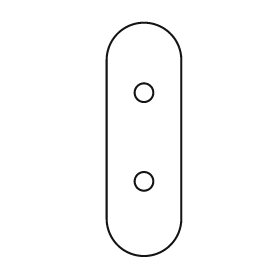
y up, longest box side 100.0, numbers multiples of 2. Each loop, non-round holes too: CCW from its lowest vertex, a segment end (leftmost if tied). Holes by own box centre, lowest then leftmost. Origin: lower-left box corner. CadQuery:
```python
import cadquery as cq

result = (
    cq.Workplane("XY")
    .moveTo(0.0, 16.0)
    .threePointArc((16.0, 0.0), (32.0, 16.0))
    .lineTo(32.0, 84.0)
    .threePointArc((16.0, 100.0), (0.0, 84.0))
    .close()
    .moveTo(16.0, 32.0)
    .circle(4.0)
    .moveTo(16.0, 70.0)
    .circle(4.0)
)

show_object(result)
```